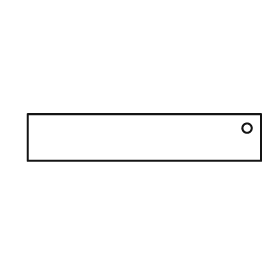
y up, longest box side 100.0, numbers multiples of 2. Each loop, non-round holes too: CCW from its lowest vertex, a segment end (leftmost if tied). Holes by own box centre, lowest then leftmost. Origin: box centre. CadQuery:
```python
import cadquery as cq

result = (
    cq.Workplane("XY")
    .moveTo(-50.0, -10.0)
    .lineTo(50.0, -10.0)
    .lineTo(50.0, 10.0)
    .lineTo(-50.0, 10.0)
    .close()
    .moveTo(44.0, 4.0)
    .circle(2.0)
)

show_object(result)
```